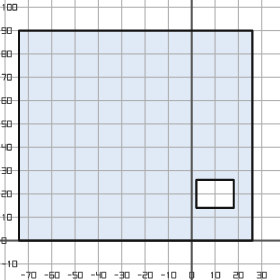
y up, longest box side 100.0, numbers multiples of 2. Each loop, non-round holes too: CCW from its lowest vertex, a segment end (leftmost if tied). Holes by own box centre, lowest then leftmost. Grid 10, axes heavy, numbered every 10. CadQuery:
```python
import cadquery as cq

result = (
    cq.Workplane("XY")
    .moveTo(-74.0, 0.0)
    .lineTo(26.0, 0.0)
    .lineTo(26.0, 90.0)
    .lineTo(-74.0, 90.0)
    .close()
    .moveTo(2.0, 14.0)
    .lineTo(18.0, 14.0)
    .lineTo(18.0, 26.0)
    .lineTo(2.0, 26.0)
    .close()
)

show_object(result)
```